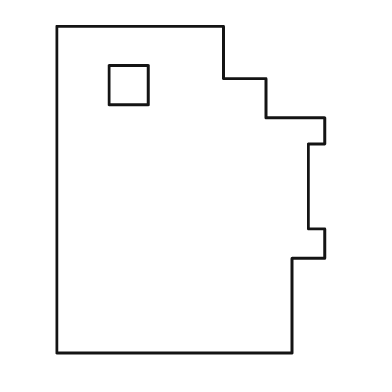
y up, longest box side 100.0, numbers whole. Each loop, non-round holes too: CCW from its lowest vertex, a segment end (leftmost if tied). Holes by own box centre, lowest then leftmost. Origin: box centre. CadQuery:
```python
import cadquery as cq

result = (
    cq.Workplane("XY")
    .moveTo(-41.0, -50.0)
    .lineTo(31.0, -50.0)
    .lineTo(31.0, -21.0)
    .lineTo(41.0, -21.0)
    .lineTo(41.0, -12.0)
    .lineTo(36.0, -12.0)
    .lineTo(36.0, 14.0)
    .lineTo(41.0, 14.0)
    .lineTo(41.0, 22.0)
    .lineTo(23.0, 22.0)
    .lineTo(23.0, 34.0)
    .lineTo(10.0, 34.0)
    .lineTo(10.0, 50.0)
    .lineTo(-41.0, 50.0)
    .close()
    .moveTo(-25.0, 26.0)
    .lineTo(-13.0, 26.0)
    .lineTo(-13.0, 38.0)
    .lineTo(-25.0, 38.0)
    .close()
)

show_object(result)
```